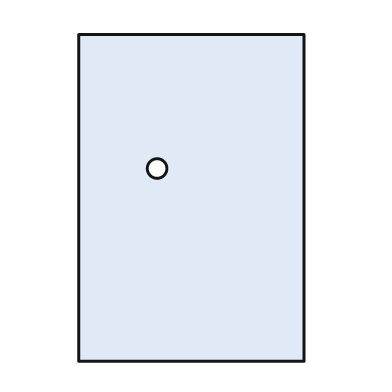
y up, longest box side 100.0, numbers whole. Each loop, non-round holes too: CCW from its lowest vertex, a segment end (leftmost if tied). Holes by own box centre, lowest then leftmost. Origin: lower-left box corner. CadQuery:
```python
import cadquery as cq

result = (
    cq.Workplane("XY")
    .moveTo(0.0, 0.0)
    .lineTo(69.0, 0.0)
    .lineTo(69.0, 100.0)
    .lineTo(0.0, 100.0)
    .close()
    .moveTo(24.0, 59.0)
    .circle(3.0)
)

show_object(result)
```